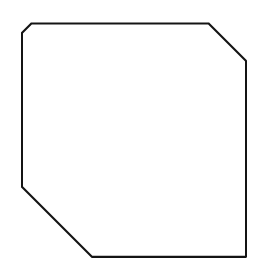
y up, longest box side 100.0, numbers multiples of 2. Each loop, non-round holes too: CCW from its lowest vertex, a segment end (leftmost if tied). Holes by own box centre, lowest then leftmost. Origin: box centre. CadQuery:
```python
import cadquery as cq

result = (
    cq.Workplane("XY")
    .moveTo(-18.0, -50.0)
    .lineTo(48.0, -50.0)
    .lineTo(48.0, 34.0)
    .lineTo(32.0, 50.0)
    .lineTo(-44.0, 50.0)
    .lineTo(-48.0, 46.0)
    .lineTo(-48.0, -20.0)
    .close()
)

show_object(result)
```